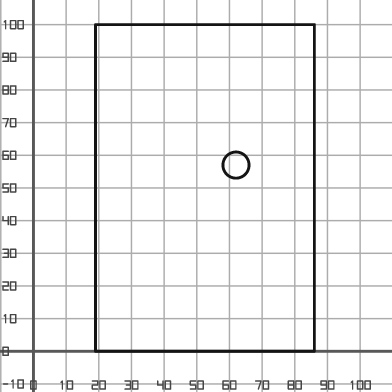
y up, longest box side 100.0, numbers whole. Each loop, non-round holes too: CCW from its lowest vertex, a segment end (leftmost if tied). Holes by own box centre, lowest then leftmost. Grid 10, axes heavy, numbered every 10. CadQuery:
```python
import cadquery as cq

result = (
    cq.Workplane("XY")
    .moveTo(19.0, 0.0)
    .lineTo(86.0, 0.0)
    .lineTo(86.0, 100.0)
    .lineTo(19.0, 100.0)
    .close()
    .moveTo(62.0, 57.0)
    .circle(4.0)
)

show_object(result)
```